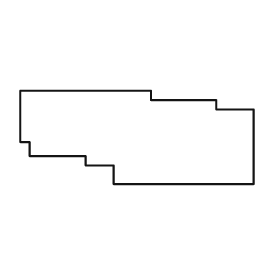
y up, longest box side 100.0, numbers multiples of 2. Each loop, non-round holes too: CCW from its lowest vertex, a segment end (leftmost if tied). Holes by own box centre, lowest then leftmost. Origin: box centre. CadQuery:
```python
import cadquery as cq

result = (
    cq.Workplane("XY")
    .moveTo(-10.0, -20.0)
    .lineTo(50.0, -20.0)
    .lineTo(50.0, 12.0)
    .lineTo(34.0, 12.0)
    .lineTo(34.0, 16.0)
    .lineTo(6.0, 16.0)
    .lineTo(6.0, 20.0)
    .lineTo(-50.0, 20.0)
    .lineTo(-50.0, -2.0)
    .lineTo(-46.0, -2.0)
    .lineTo(-46.0, -8.0)
    .lineTo(-22.0, -8.0)
    .lineTo(-22.0, -12.0)
    .lineTo(-10.0, -12.0)
    .close()
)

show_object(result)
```